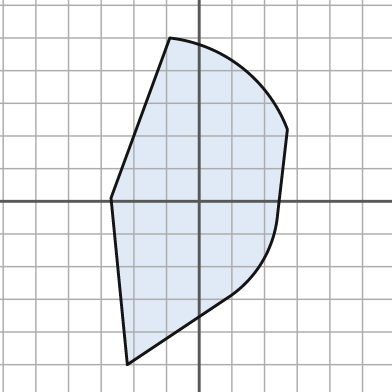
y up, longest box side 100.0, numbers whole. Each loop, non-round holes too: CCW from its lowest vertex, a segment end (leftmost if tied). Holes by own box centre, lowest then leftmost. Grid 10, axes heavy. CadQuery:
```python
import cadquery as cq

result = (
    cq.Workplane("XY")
    .moveTo(-22.0, -50.0)
    .lineTo(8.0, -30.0)
    .threePointArc((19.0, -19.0), (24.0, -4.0))
    .lineTo(27.0, 22.0)
    .threePointArc((13.0, 41.0), (-9.0, 50.0))
    .lineTo(-27.0, 1.0)
    .close()
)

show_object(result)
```